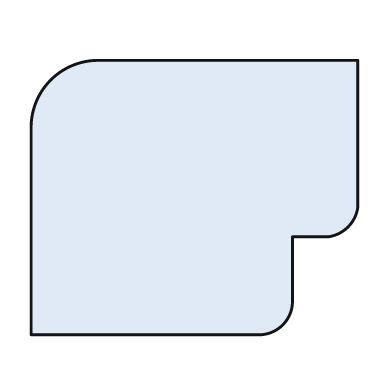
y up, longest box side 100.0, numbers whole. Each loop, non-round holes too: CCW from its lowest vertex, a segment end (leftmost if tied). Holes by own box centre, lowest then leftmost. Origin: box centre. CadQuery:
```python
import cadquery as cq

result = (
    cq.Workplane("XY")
    .moveTo(-50.0, -42.0)
    .lineTo(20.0, -42.0)
    .threePointArc((27.0, -39.0), (30.0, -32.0))
    .lineTo(30.0, -12.0)
    .lineTo(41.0, -12.0)
    .threePointArc((47.0, -9.0), (50.0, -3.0))
    .lineTo(50.0, 42.0)
    .lineTo(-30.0, 42.0)
    .threePointArc((-44.0, 36.0), (-50.0, 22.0))
    .close()
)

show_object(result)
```